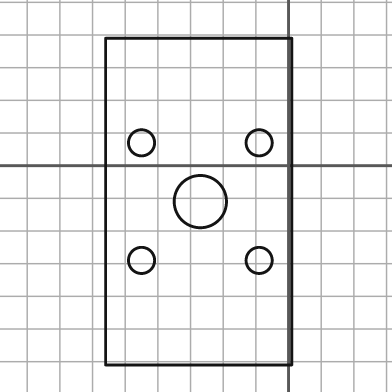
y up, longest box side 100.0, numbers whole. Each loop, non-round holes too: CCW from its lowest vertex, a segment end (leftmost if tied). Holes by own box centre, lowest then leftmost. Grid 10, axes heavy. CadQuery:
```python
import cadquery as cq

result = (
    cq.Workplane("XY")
    .moveTo(-56.0, -61.0)
    .lineTo(1.0, -61.0)
    .lineTo(1.0, 39.0)
    .lineTo(-56.0, 39.0)
    .close()
    .moveTo(-45.0, -29.0)
    .circle(4.0)
    .moveTo(-9.0, -29.0)
    .circle(4.0)
    .moveTo(-27.0, -11.0)
    .circle(8.0)
    .moveTo(-45.0, 7.0)
    .circle(4.0)
    .moveTo(-9.0, 7.0)
    .circle(4.0)
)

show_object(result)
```